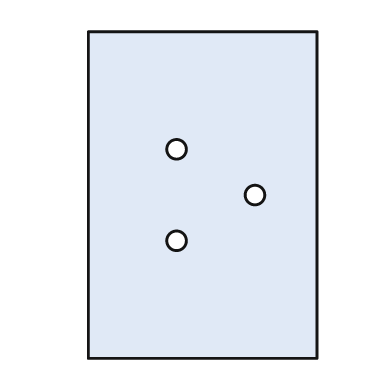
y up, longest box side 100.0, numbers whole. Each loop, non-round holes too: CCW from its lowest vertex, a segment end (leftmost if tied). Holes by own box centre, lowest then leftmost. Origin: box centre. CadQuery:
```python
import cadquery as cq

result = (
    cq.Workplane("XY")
    .moveTo(-35.0, -50.0)
    .lineTo(35.0, -50.0)
    .lineTo(35.0, 50.0)
    .lineTo(-35.0, 50.0)
    .close()
    .moveTo(-8.0, -14.0)
    .circle(3.0)
    .moveTo(16.0, 0.0)
    .circle(3.0)
    .moveTo(-8.0, 14.0)
    .circle(3.0)
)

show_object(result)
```